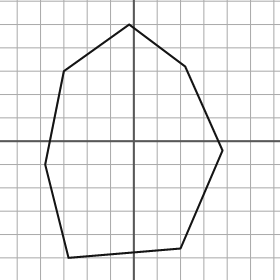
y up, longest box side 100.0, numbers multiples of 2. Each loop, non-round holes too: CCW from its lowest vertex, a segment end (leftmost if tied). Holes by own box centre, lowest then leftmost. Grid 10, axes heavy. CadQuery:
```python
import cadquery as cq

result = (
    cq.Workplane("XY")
    .moveTo(-28.0, -50.0)
    .lineTo(20.0, -46.0)
    .lineTo(38.0, -4.0)
    .lineTo(22.0, 32.0)
    .lineTo(-2.0, 50.0)
    .lineTo(-30.0, 30.0)
    .lineTo(-38.0, -10.0)
    .close()
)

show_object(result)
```